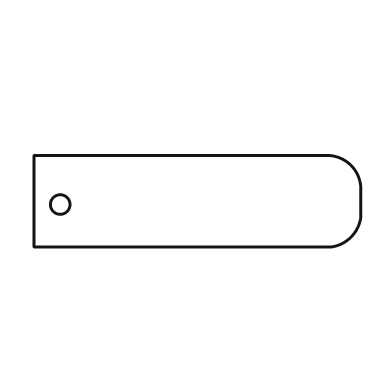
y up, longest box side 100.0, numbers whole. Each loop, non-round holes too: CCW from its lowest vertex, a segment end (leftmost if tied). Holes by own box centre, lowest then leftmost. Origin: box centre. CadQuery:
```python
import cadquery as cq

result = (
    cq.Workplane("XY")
    .moveTo(-50.0, -14.0)
    .lineTo(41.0, -14.0)
    .threePointArc((47.0, -11.0), (50.0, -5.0))
    .lineTo(50.0, 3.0)
    .threePointArc((47.0, 11.0), (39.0, 14.0))
    .lineTo(-50.0, 14.0)
    .close()
    .moveTo(-42.0, -1.0)
    .circle(3.0)
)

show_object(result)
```